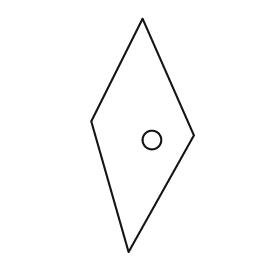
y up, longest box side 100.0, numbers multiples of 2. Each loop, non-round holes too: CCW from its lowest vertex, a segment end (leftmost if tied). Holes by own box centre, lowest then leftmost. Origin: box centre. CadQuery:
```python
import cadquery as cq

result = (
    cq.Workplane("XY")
    .moveTo(-6.0, -50.0)
    .lineTo(22.0, 0.0)
    .lineTo(0.0, 50.0)
    .lineTo(-22.0, 6.0)
    .close()
    .moveTo(4.0, -2.0)
    .circle(4.0)
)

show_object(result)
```